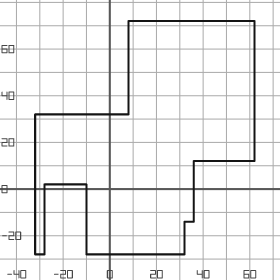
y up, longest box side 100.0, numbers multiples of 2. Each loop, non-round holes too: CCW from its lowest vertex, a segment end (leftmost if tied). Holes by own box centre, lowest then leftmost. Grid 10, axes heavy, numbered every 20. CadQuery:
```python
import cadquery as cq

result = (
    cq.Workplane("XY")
    .moveTo(-32.0, -28.0)
    .lineTo(-28.0, -28.0)
    .lineTo(-28.0, 2.0)
    .lineTo(-10.0, 2.0)
    .lineTo(-10.0, -28.0)
    .lineTo(32.0, -28.0)
    .lineTo(32.0, -14.0)
    .lineTo(36.0, -14.0)
    .lineTo(36.0, 12.0)
    .lineTo(62.0, 12.0)
    .lineTo(62.0, 72.0)
    .lineTo(8.0, 72.0)
    .lineTo(8.0, 32.0)
    .lineTo(-32.0, 32.0)
    .close()
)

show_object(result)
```